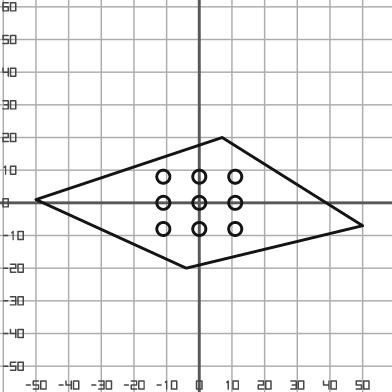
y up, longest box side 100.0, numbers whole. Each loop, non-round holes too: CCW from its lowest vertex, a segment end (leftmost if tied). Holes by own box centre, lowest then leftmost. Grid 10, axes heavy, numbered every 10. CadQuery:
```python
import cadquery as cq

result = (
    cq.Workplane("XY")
    .moveTo(-4.0, -20.0)
    .lineTo(50.0, -7.0)
    .lineTo(7.0, 20.0)
    .lineTo(-50.0, 1.0)
    .close()
    .moveTo(-11.0, -8.0)
    .circle(2.0)
    .moveTo(0.0, -8.0)
    .circle(2.0)
    .moveTo(11.0, -8.0)
    .circle(2.0)
    .moveTo(-11.0, 0.0)
    .circle(2.0)
    .moveTo(0.0, 0.0)
    .circle(2.0)
    .moveTo(11.0, 0.0)
    .circle(2.0)
    .moveTo(-11.0, 8.0)
    .circle(2.0)
    .moveTo(0.0, 8.0)
    .circle(2.0)
    .moveTo(11.0, 8.0)
    .circle(2.0)
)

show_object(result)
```